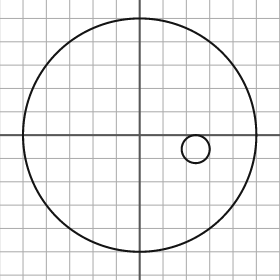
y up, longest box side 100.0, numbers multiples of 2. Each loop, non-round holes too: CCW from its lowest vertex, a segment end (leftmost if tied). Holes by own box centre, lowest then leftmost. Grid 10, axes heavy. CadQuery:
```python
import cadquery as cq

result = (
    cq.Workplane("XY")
    .moveTo(0.0, 0.0)
    .circle(50.0)
    .moveTo(24.0, -6.0)
    .circle(6.0)
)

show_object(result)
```